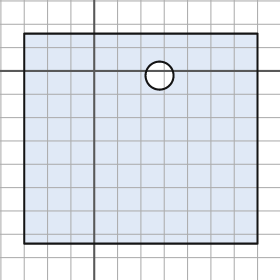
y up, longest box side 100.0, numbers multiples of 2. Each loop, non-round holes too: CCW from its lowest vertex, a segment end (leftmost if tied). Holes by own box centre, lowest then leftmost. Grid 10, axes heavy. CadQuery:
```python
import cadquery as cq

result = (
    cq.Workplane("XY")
    .moveTo(-30.0, -74.0)
    .lineTo(70.0, -74.0)
    .lineTo(70.0, 16.0)
    .lineTo(-30.0, 16.0)
    .close()
    .moveTo(28.0, -2.0)
    .circle(6.0)
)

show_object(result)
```